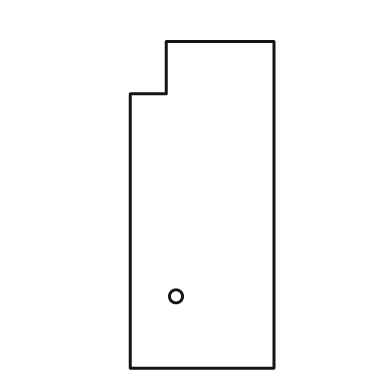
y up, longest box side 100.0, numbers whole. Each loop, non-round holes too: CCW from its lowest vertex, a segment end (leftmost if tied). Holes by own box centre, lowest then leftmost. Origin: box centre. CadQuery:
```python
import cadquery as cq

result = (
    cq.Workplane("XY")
    .moveTo(-22.0, -50.0)
    .lineTo(22.0, -50.0)
    .lineTo(22.0, 50.0)
    .lineTo(-11.0, 50.0)
    .lineTo(-11.0, 34.0)
    .lineTo(-22.0, 34.0)
    .close()
    .moveTo(-8.0, -28.0)
    .circle(2.0)
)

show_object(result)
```